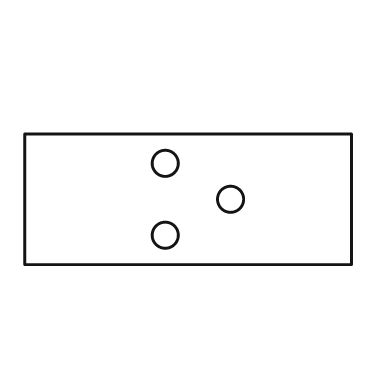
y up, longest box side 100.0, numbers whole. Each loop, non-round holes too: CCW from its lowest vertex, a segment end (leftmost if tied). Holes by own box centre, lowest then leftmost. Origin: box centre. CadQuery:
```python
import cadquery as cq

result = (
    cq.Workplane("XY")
    .moveTo(-50.0, -20.0)
    .lineTo(50.0, -20.0)
    .lineTo(50.0, 20.0)
    .lineTo(-50.0, 20.0)
    .close()
    .moveTo(-7.0, -11.0)
    .circle(4.0)
    .moveTo(13.0, 0.0)
    .circle(4.0)
    .moveTo(-7.0, 11.0)
    .circle(4.0)
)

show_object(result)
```